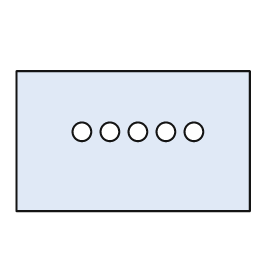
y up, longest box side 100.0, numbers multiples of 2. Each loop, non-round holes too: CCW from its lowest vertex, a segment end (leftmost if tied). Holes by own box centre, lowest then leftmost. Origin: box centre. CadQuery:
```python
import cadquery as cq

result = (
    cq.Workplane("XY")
    .moveTo(-50.0, -30.0)
    .lineTo(50.0, -30.0)
    .lineTo(50.0, 30.0)
    .lineTo(-50.0, 30.0)
    .close()
    .moveTo(-22.0, 4.0)
    .circle(4.0)
    .moveTo(-10.0, 4.0)
    .circle(4.0)
    .moveTo(2.0, 4.0)
    .circle(4.0)
    .moveTo(14.0, 4.0)
    .circle(4.0)
    .moveTo(26.0, 4.0)
    .circle(4.0)
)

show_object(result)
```